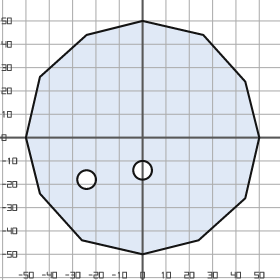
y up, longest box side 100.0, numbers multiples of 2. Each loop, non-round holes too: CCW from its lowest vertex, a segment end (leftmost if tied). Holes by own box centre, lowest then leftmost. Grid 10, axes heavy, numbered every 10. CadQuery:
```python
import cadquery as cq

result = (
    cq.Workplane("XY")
    .moveTo(0.0, -50.0)
    .lineTo(24.0, -44.0)
    .lineTo(44.0, -26.0)
    .lineTo(50.0, 0.0)
    .lineTo(44.0, 24.0)
    .lineTo(26.0, 44.0)
    .lineTo(0.0, 50.0)
    .lineTo(-24.0, 44.0)
    .lineTo(-44.0, 26.0)
    .lineTo(-50.0, 0.0)
    .lineTo(-44.0, -24.0)
    .lineTo(-26.0, -44.0)
    .close()
    .moveTo(-24.0, -18.0)
    .circle(4.0)
    .moveTo(0.0, -14.0)
    .circle(4.0)
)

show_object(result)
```